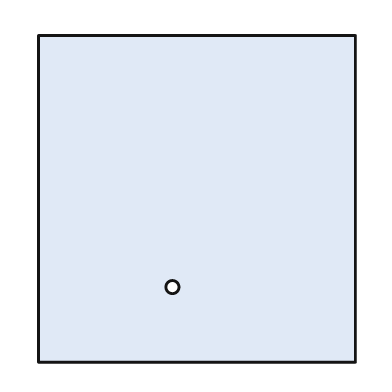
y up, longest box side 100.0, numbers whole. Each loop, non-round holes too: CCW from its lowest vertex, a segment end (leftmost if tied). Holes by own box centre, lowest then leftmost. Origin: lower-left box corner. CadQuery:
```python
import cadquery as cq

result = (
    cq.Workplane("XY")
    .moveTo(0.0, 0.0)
    .lineTo(97.0, 0.0)
    .lineTo(97.0, 100.0)
    .lineTo(0.0, 100.0)
    .close()
    .moveTo(41.0, 23.0)
    .circle(2.0)
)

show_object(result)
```